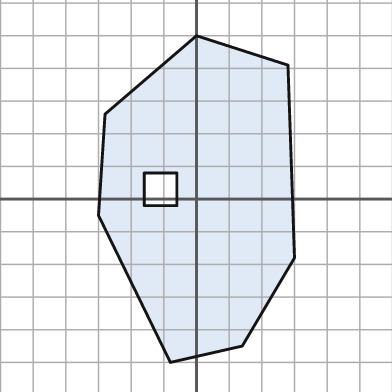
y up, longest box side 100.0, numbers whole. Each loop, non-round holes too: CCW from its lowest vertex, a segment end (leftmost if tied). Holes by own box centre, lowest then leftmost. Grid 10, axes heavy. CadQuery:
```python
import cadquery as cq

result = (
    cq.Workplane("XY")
    .moveTo(-8.0, -50.0)
    .lineTo(14.0, -45.0)
    .lineTo(30.0, -18.0)
    .lineTo(28.0, 41.0)
    .lineTo(0.0, 50.0)
    .lineTo(-28.0, 26.0)
    .lineTo(-30.0, -5.0)
    .close()
    .moveTo(-16.0, -2.0)
    .lineTo(-6.0, -2.0)
    .lineTo(-6.0, 8.0)
    .lineTo(-16.0, 8.0)
    .close()
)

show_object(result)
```